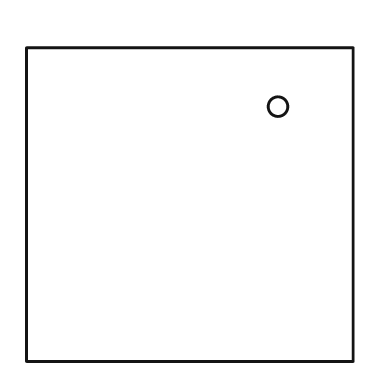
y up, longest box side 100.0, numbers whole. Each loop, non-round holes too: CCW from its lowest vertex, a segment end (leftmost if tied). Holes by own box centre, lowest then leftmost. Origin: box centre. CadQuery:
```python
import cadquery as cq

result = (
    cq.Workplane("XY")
    .moveTo(-50.0, -48.0)
    .lineTo(50.0, -48.0)
    .lineTo(50.0, 48.0)
    .lineTo(-50.0, 48.0)
    .close()
    .moveTo(27.0, 30.0)
    .circle(3.0)
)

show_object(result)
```